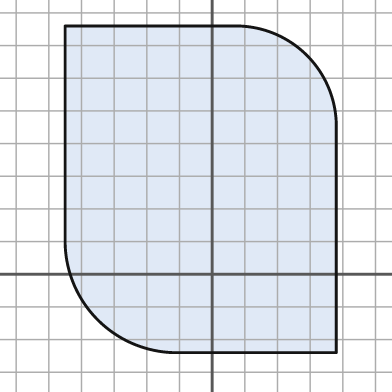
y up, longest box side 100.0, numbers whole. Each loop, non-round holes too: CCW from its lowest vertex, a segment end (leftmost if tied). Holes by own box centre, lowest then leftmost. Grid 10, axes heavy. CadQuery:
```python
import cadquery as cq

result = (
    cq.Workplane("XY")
    .moveTo(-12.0, -24.0)
    .lineTo(38.0, -24.0)
    .lineTo(38.0, 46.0)
    .threePointArc((29.0, 67.0), (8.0, 76.0))
    .lineTo(-45.0, 76.0)
    .lineTo(-45.0, 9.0)
    .threePointArc((-35.0, -14.0), (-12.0, -24.0))
    .close()
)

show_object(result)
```